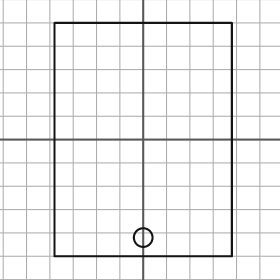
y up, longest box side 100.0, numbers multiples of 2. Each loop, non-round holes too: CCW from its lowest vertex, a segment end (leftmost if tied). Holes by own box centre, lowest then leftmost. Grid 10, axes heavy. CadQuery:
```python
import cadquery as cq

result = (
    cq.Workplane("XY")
    .moveTo(-38.0, -50.0)
    .lineTo(38.0, -50.0)
    .lineTo(38.0, 50.0)
    .lineTo(-38.0, 50.0)
    .close()
    .moveTo(0.0, -42.0)
    .circle(4.0)
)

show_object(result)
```